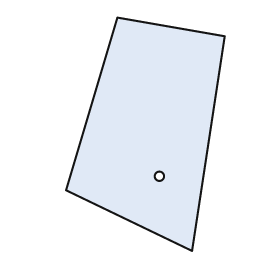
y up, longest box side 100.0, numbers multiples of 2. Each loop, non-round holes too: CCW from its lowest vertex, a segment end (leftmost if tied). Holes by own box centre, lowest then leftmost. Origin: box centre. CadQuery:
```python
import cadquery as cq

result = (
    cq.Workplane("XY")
    .moveTo(20.0, -50.0)
    .lineTo(34.0, 42.0)
    .lineTo(-12.0, 50.0)
    .lineTo(-34.0, -24.0)
    .close()
    .moveTo(6.0, -18.0)
    .circle(2.0)
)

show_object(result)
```